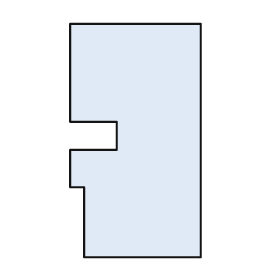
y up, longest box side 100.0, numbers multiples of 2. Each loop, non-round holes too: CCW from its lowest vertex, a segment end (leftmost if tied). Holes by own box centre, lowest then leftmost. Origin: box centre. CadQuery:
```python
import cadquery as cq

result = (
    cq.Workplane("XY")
    .moveTo(-22.0, -50.0)
    .lineTo(28.0, -50.0)
    .lineTo(28.0, 50.0)
    .lineTo(-28.0, 50.0)
    .lineTo(-28.0, 8.0)
    .lineTo(-8.0, 8.0)
    .lineTo(-8.0, -4.0)
    .lineTo(-28.0, -4.0)
    .lineTo(-28.0, -20.0)
    .lineTo(-22.0, -20.0)
    .close()
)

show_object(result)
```